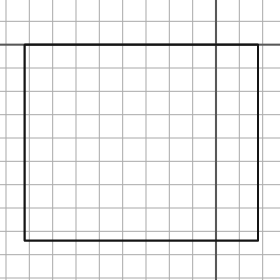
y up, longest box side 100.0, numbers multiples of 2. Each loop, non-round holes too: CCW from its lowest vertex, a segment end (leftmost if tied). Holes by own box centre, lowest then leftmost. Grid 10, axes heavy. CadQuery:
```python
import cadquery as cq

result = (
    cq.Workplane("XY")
    .moveTo(-82.0, -84.0)
    .lineTo(18.0, -84.0)
    .lineTo(18.0, 0.0)
    .lineTo(-82.0, 0.0)
    .close()
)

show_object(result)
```